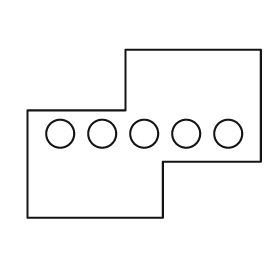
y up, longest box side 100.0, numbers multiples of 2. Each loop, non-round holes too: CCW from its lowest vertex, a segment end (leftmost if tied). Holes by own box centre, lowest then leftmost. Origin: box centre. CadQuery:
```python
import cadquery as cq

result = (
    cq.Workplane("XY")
    .moveTo(-50.0, -36.0)
    .lineTo(8.0, -36.0)
    .lineTo(8.0, -12.0)
    .lineTo(50.0, -12.0)
    .lineTo(50.0, 36.0)
    .lineTo(-8.0, 36.0)
    .lineTo(-8.0, 10.0)
    .lineTo(-50.0, 10.0)
    .close()
    .moveTo(-36.0, 0.0)
    .circle(6.0)
    .moveTo(-18.0, 0.0)
    .circle(6.0)
    .moveTo(0.0, 0.0)
    .circle(6.0)
    .moveTo(18.0, 0.0)
    .circle(6.0)
    .moveTo(36.0, 0.0)
    .circle(6.0)
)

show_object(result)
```